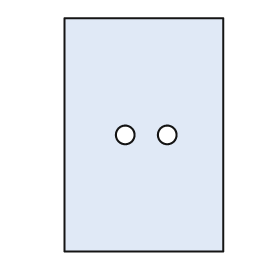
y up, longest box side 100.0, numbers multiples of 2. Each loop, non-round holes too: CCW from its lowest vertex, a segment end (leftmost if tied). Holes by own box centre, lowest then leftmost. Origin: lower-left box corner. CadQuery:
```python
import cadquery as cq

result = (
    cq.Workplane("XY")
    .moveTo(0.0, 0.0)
    .lineTo(68.0, 0.0)
    .lineTo(68.0, 100.0)
    .lineTo(0.0, 100.0)
    .close()
    .moveTo(26.0, 50.0)
    .circle(4.0)
    .moveTo(44.0, 50.0)
    .circle(4.0)
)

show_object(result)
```